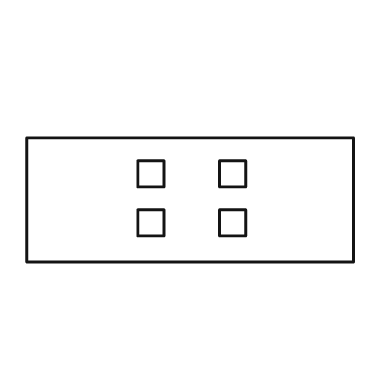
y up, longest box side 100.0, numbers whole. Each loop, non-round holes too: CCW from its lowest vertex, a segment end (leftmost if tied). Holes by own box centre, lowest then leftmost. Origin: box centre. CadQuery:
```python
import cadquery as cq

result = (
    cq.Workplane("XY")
    .moveTo(-50.0, -19.0)
    .lineTo(50.0, -19.0)
    .lineTo(50.0, 19.0)
    .lineTo(-50.0, 19.0)
    .close()
    .moveTo(-16.0, -11.0)
    .lineTo(-8.0, -11.0)
    .lineTo(-8.0, -3.0)
    .lineTo(-16.0, -3.0)
    .close()
    .moveTo(9.0, -11.0)
    .lineTo(17.0, -11.0)
    .lineTo(17.0, -3.0)
    .lineTo(9.0, -3.0)
    .close()
    .moveTo(-16.0, 4.0)
    .lineTo(-8.0, 4.0)
    .lineTo(-8.0, 12.0)
    .lineTo(-16.0, 12.0)
    .close()
    .moveTo(9.0, 4.0)
    .lineTo(17.0, 4.0)
    .lineTo(17.0, 12.0)
    .lineTo(9.0, 12.0)
    .close()
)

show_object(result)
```